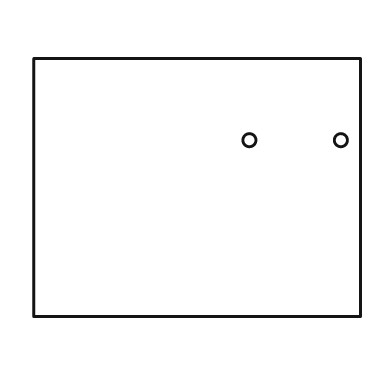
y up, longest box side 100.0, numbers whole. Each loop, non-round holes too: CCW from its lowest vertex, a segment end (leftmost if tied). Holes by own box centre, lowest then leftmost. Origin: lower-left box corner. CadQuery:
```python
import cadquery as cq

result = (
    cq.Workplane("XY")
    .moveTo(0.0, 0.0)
    .lineTo(100.0, 0.0)
    .lineTo(100.0, 79.0)
    .lineTo(0.0, 79.0)
    .close()
    .moveTo(66.0, 54.0)
    .circle(2.0)
    .moveTo(94.0, 54.0)
    .circle(2.0)
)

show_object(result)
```